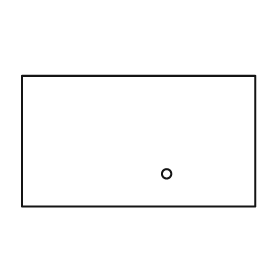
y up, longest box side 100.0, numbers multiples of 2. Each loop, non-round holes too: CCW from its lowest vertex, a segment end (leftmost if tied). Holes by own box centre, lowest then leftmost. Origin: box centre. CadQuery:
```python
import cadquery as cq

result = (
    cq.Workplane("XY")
    .moveTo(-50.0, -28.0)
    .lineTo(50.0, -28.0)
    .lineTo(50.0, 28.0)
    .lineTo(-50.0, 28.0)
    .close()
    .moveTo(12.0, -14.0)
    .circle(2.0)
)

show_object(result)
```